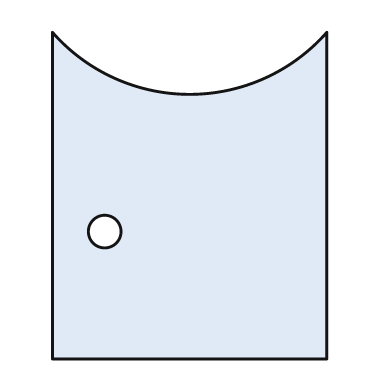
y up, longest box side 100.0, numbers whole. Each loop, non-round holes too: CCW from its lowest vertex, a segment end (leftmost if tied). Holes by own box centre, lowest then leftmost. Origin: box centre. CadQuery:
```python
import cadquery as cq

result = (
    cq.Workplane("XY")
    .moveTo(-42.0, -50.0)
    .lineTo(42.0, -50.0)
    .lineTo(42.0, 50.0)
    .threePointArc((0.0, 31.0), (-42.0, 50.0))
    .close()
    .moveTo(-26.0, -11.0)
    .circle(5.0)
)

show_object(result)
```